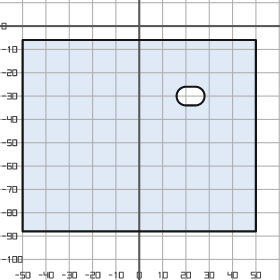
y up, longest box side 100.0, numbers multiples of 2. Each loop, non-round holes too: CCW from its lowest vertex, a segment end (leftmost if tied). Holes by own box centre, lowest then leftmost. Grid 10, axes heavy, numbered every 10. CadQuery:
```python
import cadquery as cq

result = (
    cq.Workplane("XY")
    .moveTo(-50.0, -88.0)
    .lineTo(50.0, -88.0)
    .lineTo(50.0, -6.0)
    .lineTo(-50.0, -6.0)
    .close()
    .moveTo(20.0, -34.0)
    .lineTo(24.0, -34.0)
    .threePointArc((28.0, -30.0), (24.0, -26.0))
    .lineTo(20.0, -26.0)
    .threePointArc((16.0, -30.0), (20.0, -34.0))
    .close()
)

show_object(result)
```